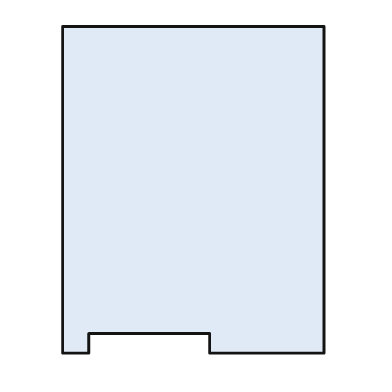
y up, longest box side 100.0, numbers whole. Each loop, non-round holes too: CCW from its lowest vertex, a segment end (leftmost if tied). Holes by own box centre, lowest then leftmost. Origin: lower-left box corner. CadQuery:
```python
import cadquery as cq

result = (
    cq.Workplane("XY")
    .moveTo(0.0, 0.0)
    .lineTo(8.0, 0.0)
    .lineTo(8.0, 6.0)
    .lineTo(45.0, 6.0)
    .lineTo(45.0, 0.0)
    .lineTo(80.0, 0.0)
    .lineTo(80.0, 100.0)
    .lineTo(0.0, 100.0)
    .close()
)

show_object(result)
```